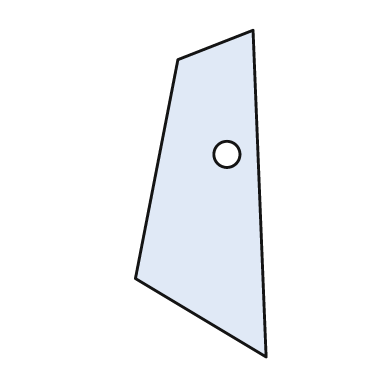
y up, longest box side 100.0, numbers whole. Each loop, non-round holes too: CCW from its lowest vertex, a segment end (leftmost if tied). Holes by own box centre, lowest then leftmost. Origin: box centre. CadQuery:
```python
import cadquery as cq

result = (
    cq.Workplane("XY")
    .moveTo(20.0, -50.0)
    .lineTo(16.0, 50.0)
    .lineTo(-7.0, 41.0)
    .lineTo(-20.0, -26.0)
    .close()
    .moveTo(8.0, 12.0)
    .circle(4.0)
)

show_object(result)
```